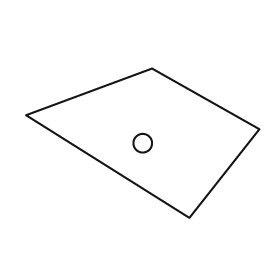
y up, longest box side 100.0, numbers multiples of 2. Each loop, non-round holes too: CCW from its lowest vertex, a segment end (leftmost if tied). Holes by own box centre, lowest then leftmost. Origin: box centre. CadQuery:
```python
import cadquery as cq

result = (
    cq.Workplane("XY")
    .moveTo(20.0, -32.0)
    .lineTo(50.0, 6.0)
    .lineTo(4.0, 32.0)
    .lineTo(-50.0, 12.0)
    .close()
    .moveTo(0.0, 0.0)
    .circle(4.0)
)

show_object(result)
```